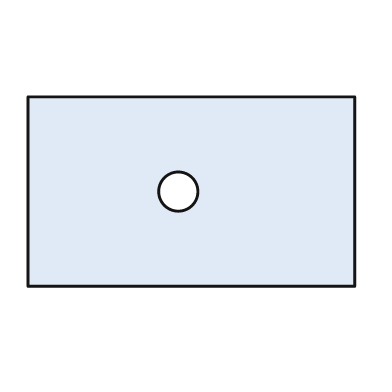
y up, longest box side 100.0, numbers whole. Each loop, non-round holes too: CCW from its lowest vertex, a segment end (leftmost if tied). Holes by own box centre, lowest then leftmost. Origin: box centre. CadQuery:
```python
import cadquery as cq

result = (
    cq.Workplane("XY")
    .moveTo(-50.0, -29.0)
    .lineTo(50.0, -29.0)
    .lineTo(50.0, 29.0)
    .lineTo(-50.0, 29.0)
    .close()
    .moveTo(-4.0, 0.0)
    .circle(6.0)
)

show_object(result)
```